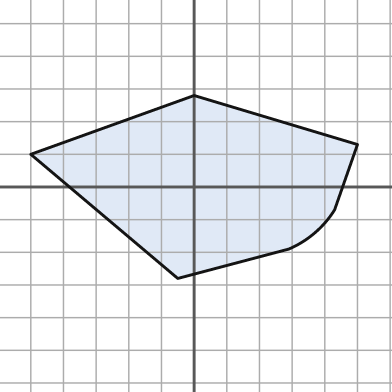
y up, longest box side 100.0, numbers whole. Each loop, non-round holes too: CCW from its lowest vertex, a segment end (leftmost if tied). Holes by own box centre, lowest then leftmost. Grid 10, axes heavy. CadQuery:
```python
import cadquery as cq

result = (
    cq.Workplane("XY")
    .moveTo(-5.0, -28.0)
    .lineTo(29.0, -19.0)
    .threePointArc((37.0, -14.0), (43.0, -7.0))
    .lineTo(50.0, 13.0)
    .lineTo(0.0, 28.0)
    .lineTo(-50.0, 10.0)
    .close()
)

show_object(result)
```